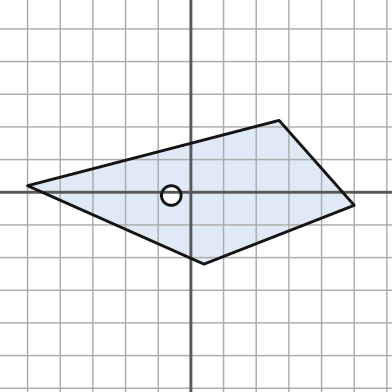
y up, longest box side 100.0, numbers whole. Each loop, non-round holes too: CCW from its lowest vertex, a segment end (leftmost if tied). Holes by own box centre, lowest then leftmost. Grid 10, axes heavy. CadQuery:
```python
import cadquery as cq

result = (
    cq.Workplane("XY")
    .moveTo(4.0, -22.0)
    .lineTo(50.0, -4.0)
    .lineTo(27.0, 22.0)
    .lineTo(-50.0, 2.0)
    .close()
    .moveTo(-6.0, -1.0)
    .circle(3.0)
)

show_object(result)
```